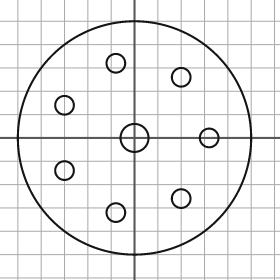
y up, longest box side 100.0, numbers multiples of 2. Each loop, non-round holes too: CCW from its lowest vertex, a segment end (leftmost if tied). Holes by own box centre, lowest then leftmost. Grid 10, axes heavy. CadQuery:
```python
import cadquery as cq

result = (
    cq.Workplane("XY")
    .moveTo(0.0, 0.0)
    .circle(50.0)
    .moveTo(-8.0, -32.0)
    .circle(4.0)
    .moveTo(20.0, -26.0)
    .circle(4.0)
    .moveTo(-30.0, -14.0)
    .circle(4.0)
    .moveTo(0.0, 0.0)
    .circle(6.0)
    .moveTo(32.0, 0.0)
    .circle(4.0)
    .moveTo(-30.0, 14.0)
    .circle(4.0)
    .moveTo(20.0, 26.0)
    .circle(4.0)
    .moveTo(-8.0, 32.0)
    .circle(4.0)
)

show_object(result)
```